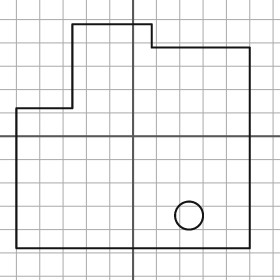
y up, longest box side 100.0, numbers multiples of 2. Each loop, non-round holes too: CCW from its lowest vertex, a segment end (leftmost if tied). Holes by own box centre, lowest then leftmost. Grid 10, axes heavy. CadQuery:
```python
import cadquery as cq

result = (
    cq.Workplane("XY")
    .moveTo(-50.0, -48.0)
    .lineTo(50.0, -48.0)
    .lineTo(50.0, 38.0)
    .lineTo(8.0, 38.0)
    .lineTo(8.0, 48.0)
    .lineTo(-26.0, 48.0)
    .lineTo(-26.0, 12.0)
    .lineTo(-50.0, 12.0)
    .close()
    .moveTo(24.0, -34.0)
    .circle(6.0)
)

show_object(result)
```